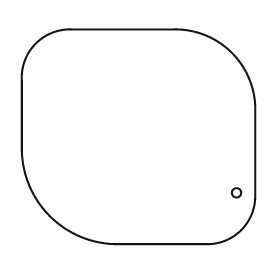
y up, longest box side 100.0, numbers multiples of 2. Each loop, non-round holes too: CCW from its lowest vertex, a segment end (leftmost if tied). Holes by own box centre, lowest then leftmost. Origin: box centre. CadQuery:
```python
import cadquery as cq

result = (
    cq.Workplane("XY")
    .moveTo(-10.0, -46.0)
    .lineTo(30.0, -46.0)
    .threePointArc((44.0, -40.0), (50.0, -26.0))
    .lineTo(50.0, 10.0)
    .threePointArc((40.0, 36.0), (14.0, 46.0))
    .lineTo(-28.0, 46.0)
    .threePointArc((-44.0, 40.0), (-50.0, 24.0))
    .lineTo(-50.0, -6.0)
    .threePointArc((-38.0, -34.0), (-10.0, -46.0))
    .close()
    .moveTo(42.0, -24.0)
    .circle(2.0)
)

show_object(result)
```